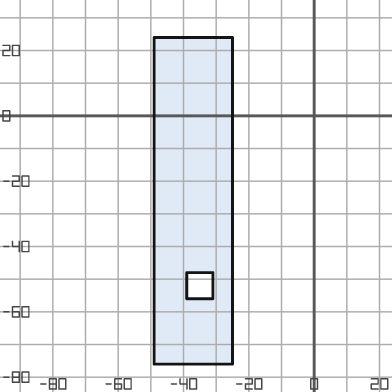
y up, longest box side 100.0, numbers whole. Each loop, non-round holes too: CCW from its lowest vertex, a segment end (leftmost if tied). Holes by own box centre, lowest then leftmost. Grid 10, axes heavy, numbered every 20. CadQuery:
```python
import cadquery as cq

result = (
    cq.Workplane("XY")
    .moveTo(-49.0, -76.0)
    .lineTo(-25.0, -76.0)
    .lineTo(-25.0, 24.0)
    .lineTo(-49.0, 24.0)
    .close()
    .moveTo(-39.0, -56.0)
    .lineTo(-31.0, -56.0)
    .lineTo(-31.0, -48.0)
    .lineTo(-39.0, -48.0)
    .close()
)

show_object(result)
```